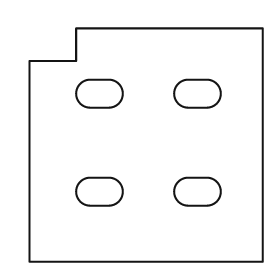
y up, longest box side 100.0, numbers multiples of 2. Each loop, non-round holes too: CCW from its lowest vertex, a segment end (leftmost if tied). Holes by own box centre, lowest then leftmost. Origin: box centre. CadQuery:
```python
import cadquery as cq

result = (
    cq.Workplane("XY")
    .moveTo(-50.0, -50.0)
    .lineTo(50.0, -50.0)
    .lineTo(50.0, 50.0)
    .lineTo(-30.0, 50.0)
    .lineTo(-30.0, 36.0)
    .lineTo(-50.0, 36.0)
    .close()
    .moveTo(-24.0, -26.0)
    .lineTo(-16.0, -26.0)
    .threePointArc((-10.0, -20.0), (-16.0, -14.0))
    .lineTo(-24.0, -14.0)
    .threePointArc((-30.0, -20.0), (-24.0, -26.0))
    .close()
    .moveTo(18.0, -26.0)
    .lineTo(26.0, -26.0)
    .threePointArc((32.0, -20.0), (26.0, -14.0))
    .lineTo(18.0, -14.0)
    .threePointArc((12.0, -20.0), (18.0, -26.0))
    .close()
    .moveTo(-24.0, 16.0)
    .lineTo(-16.0, 16.0)
    .threePointArc((-10.0, 22.0), (-16.0, 28.0))
    .lineTo(-24.0, 28.0)
    .threePointArc((-30.0, 22.0), (-24.0, 16.0))
    .close()
    .moveTo(18.0, 16.0)
    .lineTo(26.0, 16.0)
    .threePointArc((32.0, 22.0), (26.0, 28.0))
    .lineTo(18.0, 28.0)
    .threePointArc((12.0, 22.0), (18.0, 16.0))
    .close()
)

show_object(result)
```